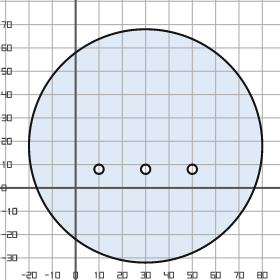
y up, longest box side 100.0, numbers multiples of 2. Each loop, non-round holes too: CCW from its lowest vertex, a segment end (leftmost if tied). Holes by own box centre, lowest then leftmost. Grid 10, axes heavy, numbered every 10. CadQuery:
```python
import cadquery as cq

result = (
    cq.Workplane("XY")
    .moveTo(30.0, 18.0)
    .circle(50.0)
    .moveTo(10.0, 8.0)
    .circle(2.0)
    .moveTo(30.0, 8.0)
    .circle(2.0)
    .moveTo(50.0, 8.0)
    .circle(2.0)
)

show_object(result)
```